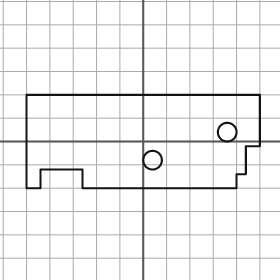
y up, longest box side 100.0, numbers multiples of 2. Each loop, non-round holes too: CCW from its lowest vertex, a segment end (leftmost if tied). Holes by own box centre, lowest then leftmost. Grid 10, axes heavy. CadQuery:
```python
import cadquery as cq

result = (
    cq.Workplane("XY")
    .moveTo(-50.0, -20.0)
    .lineTo(-44.0, -20.0)
    .lineTo(-44.0, -12.0)
    .lineTo(-26.0, -12.0)
    .lineTo(-26.0, -20.0)
    .lineTo(40.0, -20.0)
    .lineTo(40.0, -14.0)
    .lineTo(44.0, -14.0)
    .lineTo(44.0, -2.0)
    .lineTo(50.0, -2.0)
    .lineTo(50.0, 20.0)
    .lineTo(-50.0, 20.0)
    .close()
    .moveTo(4.0, -8.0)
    .circle(4.0)
    .moveTo(36.0, 4.0)
    .circle(4.0)
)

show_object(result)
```